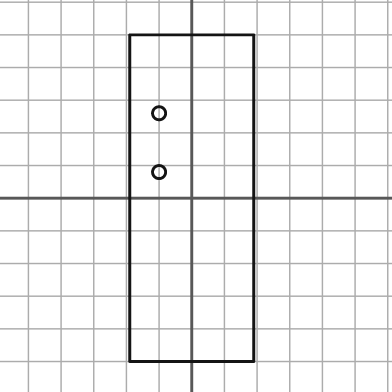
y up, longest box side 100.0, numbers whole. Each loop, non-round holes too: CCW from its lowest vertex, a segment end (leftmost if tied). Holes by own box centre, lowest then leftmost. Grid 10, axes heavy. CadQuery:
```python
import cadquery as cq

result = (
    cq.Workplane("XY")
    .moveTo(-19.0, -50.0)
    .lineTo(19.0, -50.0)
    .lineTo(19.0, 50.0)
    .lineTo(-19.0, 50.0)
    .close()
    .moveTo(-10.0, 8.0)
    .circle(2.0)
    .moveTo(-10.0, 26.0)
    .circle(2.0)
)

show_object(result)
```